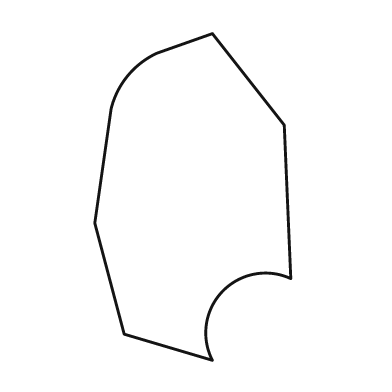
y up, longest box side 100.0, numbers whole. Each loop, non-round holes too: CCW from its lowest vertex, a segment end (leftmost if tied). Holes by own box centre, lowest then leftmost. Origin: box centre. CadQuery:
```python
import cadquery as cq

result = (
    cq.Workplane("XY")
    .moveTo(6.0, -50.0)
    .threePointArc((9.0, -29.0), (30.0, -25.0))
    .lineTo(28.0, 22.0)
    .lineTo(6.0, 50.0)
    .lineTo(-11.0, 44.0)
    .threePointArc((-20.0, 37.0), (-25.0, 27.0))
    .lineTo(-30.0, -8.0)
    .lineTo(-21.0, -42.0)
    .close()
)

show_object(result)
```